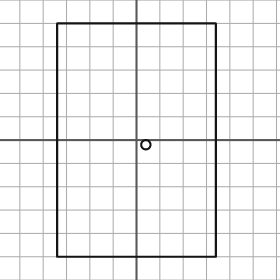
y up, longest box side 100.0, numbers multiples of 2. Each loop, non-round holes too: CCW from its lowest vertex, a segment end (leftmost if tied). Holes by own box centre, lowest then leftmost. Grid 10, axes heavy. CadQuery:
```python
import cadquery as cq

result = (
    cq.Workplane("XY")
    .moveTo(-34.0, -50.0)
    .lineTo(34.0, -50.0)
    .lineTo(34.0, 50.0)
    .lineTo(-34.0, 50.0)
    .close()
    .moveTo(4.0, -2.0)
    .circle(2.0)
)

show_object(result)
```